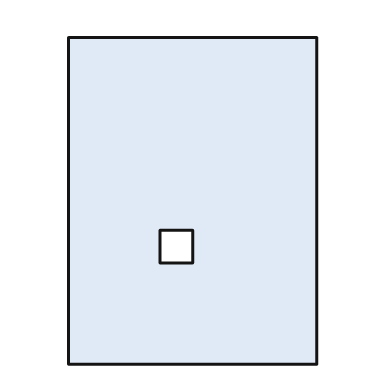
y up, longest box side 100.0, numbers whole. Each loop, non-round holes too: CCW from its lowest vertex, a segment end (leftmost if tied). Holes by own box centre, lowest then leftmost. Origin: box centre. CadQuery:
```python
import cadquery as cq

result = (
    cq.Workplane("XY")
    .moveTo(-38.0, -50.0)
    .lineTo(38.0, -50.0)
    .lineTo(38.0, 50.0)
    .lineTo(-38.0, 50.0)
    .close()
    .moveTo(-10.0, -19.0)
    .lineTo(0.0, -19.0)
    .lineTo(0.0, -9.0)
    .lineTo(-10.0, -9.0)
    .close()
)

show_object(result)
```